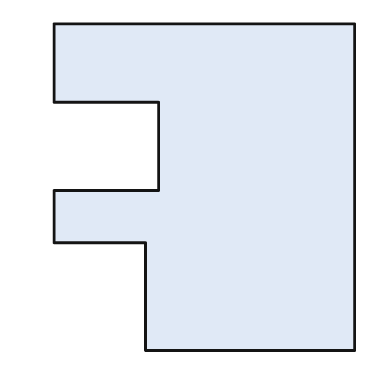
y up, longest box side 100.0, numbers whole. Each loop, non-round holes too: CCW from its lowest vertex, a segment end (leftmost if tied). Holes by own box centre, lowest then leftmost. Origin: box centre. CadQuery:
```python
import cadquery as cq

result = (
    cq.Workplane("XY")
    .moveTo(-18.0, -50.0)
    .lineTo(46.0, -50.0)
    .lineTo(46.0, 50.0)
    .lineTo(-46.0, 50.0)
    .lineTo(-46.0, 26.0)
    .lineTo(-14.0, 26.0)
    .lineTo(-14.0, -1.0)
    .lineTo(-46.0, -1.0)
    .lineTo(-46.0, -17.0)
    .lineTo(-18.0, -17.0)
    .close()
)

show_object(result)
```